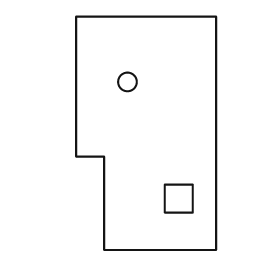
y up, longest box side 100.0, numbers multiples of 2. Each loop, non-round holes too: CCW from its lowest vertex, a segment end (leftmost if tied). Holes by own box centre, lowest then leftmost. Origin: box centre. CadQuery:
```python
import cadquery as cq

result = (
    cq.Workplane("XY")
    .moveTo(-18.0, -50.0)
    .lineTo(30.0, -50.0)
    .lineTo(30.0, 50.0)
    .lineTo(-30.0, 50.0)
    .lineTo(-30.0, -10.0)
    .lineTo(-18.0, -10.0)
    .close()
    .moveTo(8.0, -34.0)
    .lineTo(20.0, -34.0)
    .lineTo(20.0, -22.0)
    .lineTo(8.0, -22.0)
    .close()
    .moveTo(-8.0, 22.0)
    .circle(4.0)
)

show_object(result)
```